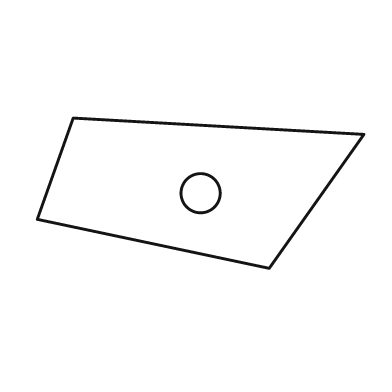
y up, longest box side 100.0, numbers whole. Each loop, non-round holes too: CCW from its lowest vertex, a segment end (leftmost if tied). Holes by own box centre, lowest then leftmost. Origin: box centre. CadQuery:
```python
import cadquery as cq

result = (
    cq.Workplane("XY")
    .moveTo(21.0, -23.0)
    .lineTo(50.0, 18.0)
    .lineTo(-39.0, 23.0)
    .lineTo(-50.0, -8.0)
    .close()
    .moveTo(0.0, 0.0)
    .circle(6.0)
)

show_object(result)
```